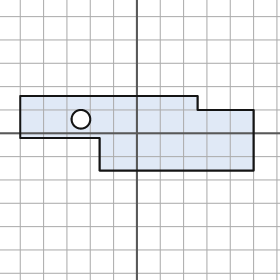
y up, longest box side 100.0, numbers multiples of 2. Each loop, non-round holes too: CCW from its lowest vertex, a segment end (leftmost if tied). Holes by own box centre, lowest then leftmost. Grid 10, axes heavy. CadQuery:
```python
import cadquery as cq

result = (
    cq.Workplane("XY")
    .moveTo(-16.0, -16.0)
    .lineTo(50.0, -16.0)
    .lineTo(50.0, 10.0)
    .lineTo(26.0, 10.0)
    .lineTo(26.0, 16.0)
    .lineTo(-50.0, 16.0)
    .lineTo(-50.0, -2.0)
    .lineTo(-16.0, -2.0)
    .close()
    .moveTo(-24.0, 6.0)
    .circle(4.0)
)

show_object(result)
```